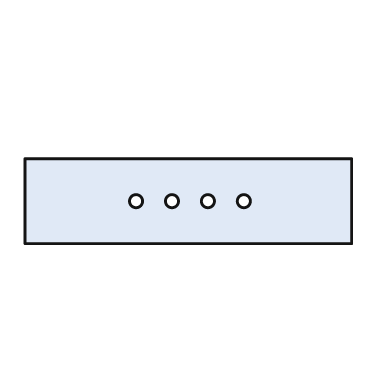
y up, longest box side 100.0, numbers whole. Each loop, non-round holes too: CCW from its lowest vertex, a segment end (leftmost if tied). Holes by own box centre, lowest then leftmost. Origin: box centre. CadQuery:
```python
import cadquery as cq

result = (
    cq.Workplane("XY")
    .moveTo(-50.0, -13.0)
    .lineTo(50.0, -13.0)
    .lineTo(50.0, 13.0)
    .lineTo(-50.0, 13.0)
    .close()
    .moveTo(-16.0, 0.0)
    .circle(2.0)
    .moveTo(-5.0, 0.0)
    .circle(2.0)
    .moveTo(6.0, 0.0)
    .circle(2.0)
    .moveTo(17.0, 0.0)
    .circle(2.0)
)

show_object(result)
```